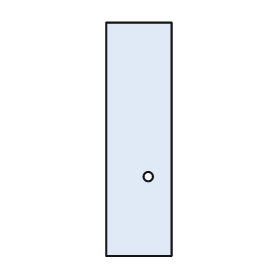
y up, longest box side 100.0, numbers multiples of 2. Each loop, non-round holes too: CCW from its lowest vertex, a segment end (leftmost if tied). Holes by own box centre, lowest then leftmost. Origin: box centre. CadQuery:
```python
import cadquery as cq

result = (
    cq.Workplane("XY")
    .moveTo(-14.0, -50.0)
    .lineTo(14.0, -50.0)
    .lineTo(14.0, 50.0)
    .lineTo(-14.0, 50.0)
    .close()
    .moveTo(4.0, -16.0)
    .circle(2.0)
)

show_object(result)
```